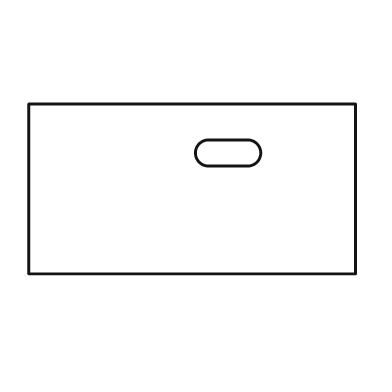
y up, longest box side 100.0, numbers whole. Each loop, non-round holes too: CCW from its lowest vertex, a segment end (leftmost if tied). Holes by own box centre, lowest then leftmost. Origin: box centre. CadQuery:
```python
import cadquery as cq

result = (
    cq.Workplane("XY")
    .moveTo(-50.0, -26.0)
    .lineTo(50.0, -26.0)
    .lineTo(50.0, 26.0)
    .lineTo(-50.0, 26.0)
    .close()
    .moveTo(5.0, 7.0)
    .lineTo(17.0, 7.0)
    .threePointArc((21.0, 11.0), (17.0, 15.0))
    .lineTo(5.0, 15.0)
    .threePointArc((1.0, 11.0), (5.0, 7.0))
    .close()
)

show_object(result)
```